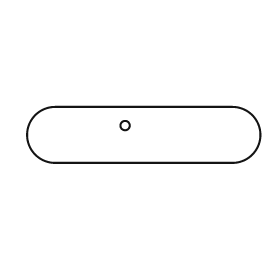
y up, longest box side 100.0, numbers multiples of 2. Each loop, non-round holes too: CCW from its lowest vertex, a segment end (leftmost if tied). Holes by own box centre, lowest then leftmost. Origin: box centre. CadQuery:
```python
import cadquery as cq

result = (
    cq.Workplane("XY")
    .moveTo(-38.0, -12.0)
    .lineTo(38.0, -12.0)
    .threePointArc((50.0, 0.0), (38.0, 12.0))
    .lineTo(-38.0, 12.0)
    .threePointArc((-50.0, 0.0), (-38.0, -12.0))
    .close()
    .moveTo(-8.0, 4.0)
    .circle(2.0)
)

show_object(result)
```